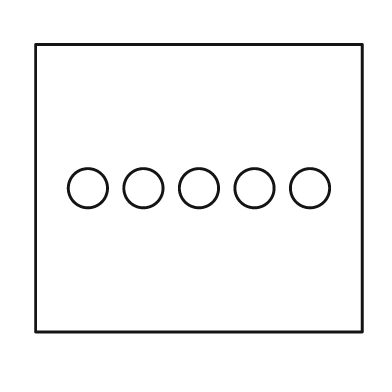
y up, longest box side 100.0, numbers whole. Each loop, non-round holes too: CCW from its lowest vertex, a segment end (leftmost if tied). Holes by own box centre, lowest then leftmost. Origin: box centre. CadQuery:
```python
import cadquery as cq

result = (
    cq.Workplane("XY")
    .moveTo(-50.0, -44.0)
    .lineTo(50.0, -44.0)
    .lineTo(50.0, 44.0)
    .lineTo(-50.0, 44.0)
    .close()
    .moveTo(-34.0, 0.0)
    .circle(6.0)
    .moveTo(-17.0, 0.0)
    .circle(6.0)
    .moveTo(0.0, 0.0)
    .circle(6.0)
    .moveTo(17.0, 0.0)
    .circle(6.0)
    .moveTo(34.0, 0.0)
    .circle(6.0)
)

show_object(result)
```